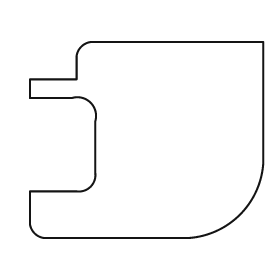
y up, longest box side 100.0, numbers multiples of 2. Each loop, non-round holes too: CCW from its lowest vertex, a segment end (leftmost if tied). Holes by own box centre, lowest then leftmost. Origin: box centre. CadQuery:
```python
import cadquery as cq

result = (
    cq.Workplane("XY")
    .moveTo(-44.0, -42.0)
    .lineTo(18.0, -42.0)
    .threePointArc((40.0, -32.0), (50.0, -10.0))
    .lineTo(50.0, 42.0)
    .lineTo(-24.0, 42.0)
    .threePointArc((-28.0, 40.0), (-30.0, 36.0))
    .lineTo(-30.0, 26.0)
    .lineTo(-50.0, 26.0)
    .lineTo(-50.0, 18.0)
    .lineTo(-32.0, 18.0)
    .threePointArc((-24.0, 16.0), (-22.0, 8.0))
    .lineTo(-22.0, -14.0)
    .threePointArc((-24.0, -20.0), (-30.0, -22.0))
    .lineTo(-50.0, -22.0)
    .lineTo(-50.0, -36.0)
    .threePointArc((-48.0, -40.0), (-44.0, -42.0))
    .close()
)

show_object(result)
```